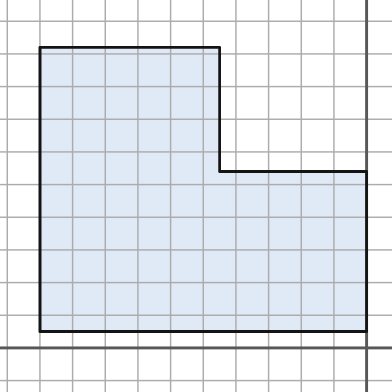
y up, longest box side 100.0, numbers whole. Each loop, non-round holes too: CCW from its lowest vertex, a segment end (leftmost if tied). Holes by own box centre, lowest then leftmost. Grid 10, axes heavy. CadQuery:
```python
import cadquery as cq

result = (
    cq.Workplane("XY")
    .moveTo(-100.0, 5.0)
    .lineTo(0.0, 5.0)
    .lineTo(0.0, 54.0)
    .lineTo(-45.0, 54.0)
    .lineTo(-45.0, 92.0)
    .lineTo(-100.0, 92.0)
    .close()
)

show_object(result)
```